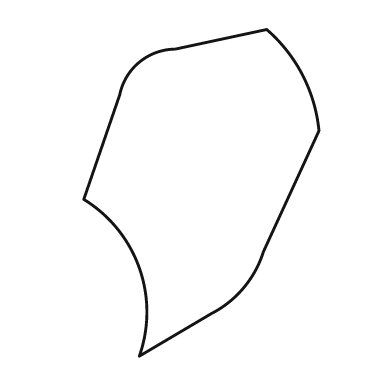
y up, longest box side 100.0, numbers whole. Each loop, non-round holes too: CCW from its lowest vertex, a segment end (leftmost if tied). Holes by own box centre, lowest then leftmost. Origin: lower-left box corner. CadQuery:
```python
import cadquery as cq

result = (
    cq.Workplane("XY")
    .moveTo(17.0, 0.0)
    .lineTo(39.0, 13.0)
    .threePointArc((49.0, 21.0), (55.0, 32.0))
    .lineTo(72.0, 69.0)
    .threePointArc((67.0, 86.0), (56.0, 100.0))
    .lineTo(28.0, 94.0)
    .threePointArc((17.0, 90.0), (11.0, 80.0))
    .lineTo(0.0, 48.0)
    .threePointArc((17.0, 27.0), (17.0, 0.0))
    .close()
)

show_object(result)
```